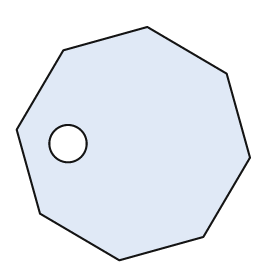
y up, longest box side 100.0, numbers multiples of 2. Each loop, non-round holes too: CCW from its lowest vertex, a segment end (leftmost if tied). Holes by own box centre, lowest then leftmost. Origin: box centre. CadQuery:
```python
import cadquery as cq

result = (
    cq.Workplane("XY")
    .moveTo(-6.0, -50.0)
    .lineTo(30.0, -40.0)
    .lineTo(50.0, -6.0)
    .lineTo(40.0, 30.0)
    .lineTo(6.0, 50.0)
    .lineTo(-30.0, 40.0)
    .lineTo(-50.0, 6.0)
    .lineTo(-40.0, -30.0)
    .close()
    .moveTo(-28.0, 0.0)
    .circle(8.0)
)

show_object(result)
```